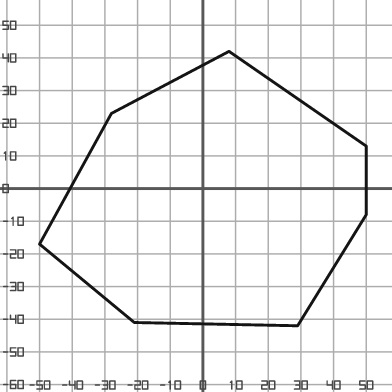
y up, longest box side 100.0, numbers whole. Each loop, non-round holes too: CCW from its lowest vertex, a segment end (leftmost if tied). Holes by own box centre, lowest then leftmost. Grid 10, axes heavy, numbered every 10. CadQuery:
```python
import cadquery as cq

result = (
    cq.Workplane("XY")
    .moveTo(29.0, -42.0)
    .lineTo(50.0, -8.0)
    .lineTo(50.0, 13.0)
    .lineTo(8.0, 42.0)
    .lineTo(-28.0, 23.0)
    .lineTo(-50.0, -17.0)
    .lineTo(-21.0, -41.0)
    .close()
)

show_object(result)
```